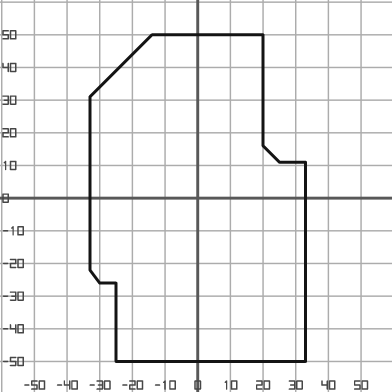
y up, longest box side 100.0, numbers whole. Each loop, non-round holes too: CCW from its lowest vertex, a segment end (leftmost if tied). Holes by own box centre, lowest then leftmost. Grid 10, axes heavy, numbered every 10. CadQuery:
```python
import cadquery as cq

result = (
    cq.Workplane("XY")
    .moveTo(-25.0, -50.0)
    .lineTo(33.0, -50.0)
    .lineTo(33.0, 11.0)
    .lineTo(25.0, 11.0)
    .lineTo(20.0, 16.0)
    .lineTo(20.0, 50.0)
    .lineTo(-14.0, 50.0)
    .lineTo(-33.0, 31.0)
    .lineTo(-33.0, -22.0)
    .lineTo(-30.0, -26.0)
    .lineTo(-25.0, -26.0)
    .close()
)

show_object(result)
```